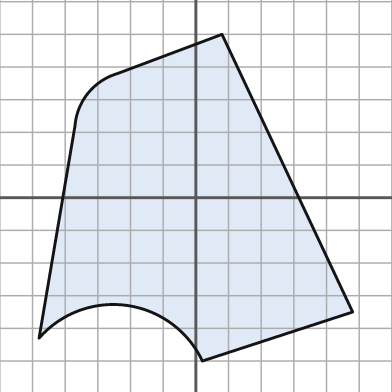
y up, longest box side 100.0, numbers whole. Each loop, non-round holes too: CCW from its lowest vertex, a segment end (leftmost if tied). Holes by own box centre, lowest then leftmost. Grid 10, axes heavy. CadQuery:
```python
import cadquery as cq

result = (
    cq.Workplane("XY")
    .moveTo(2.0, -50.0)
    .lineTo(48.0, -35.0)
    .lineTo(8.0, 50.0)
    .lineTo(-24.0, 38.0)
    .threePointArc((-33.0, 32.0), (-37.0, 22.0))
    .lineTo(-48.0, -43.0)
    .threePointArc((-21.0, -33.0), (2.0, -50.0))
    .close()
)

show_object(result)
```